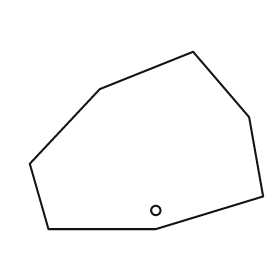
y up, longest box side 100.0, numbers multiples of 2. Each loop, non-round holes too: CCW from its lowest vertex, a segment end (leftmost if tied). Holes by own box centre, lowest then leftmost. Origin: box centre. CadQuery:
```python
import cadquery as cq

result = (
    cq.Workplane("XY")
    .moveTo(-42.0, -38.0)
    .lineTo(4.0, -38.0)
    .lineTo(50.0, -24.0)
    .lineTo(44.0, 10.0)
    .lineTo(20.0, 38.0)
    .lineTo(-20.0, 22.0)
    .lineTo(-50.0, -10.0)
    .close()
    .moveTo(4.0, -30.0)
    .circle(2.0)
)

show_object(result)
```